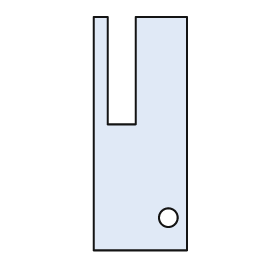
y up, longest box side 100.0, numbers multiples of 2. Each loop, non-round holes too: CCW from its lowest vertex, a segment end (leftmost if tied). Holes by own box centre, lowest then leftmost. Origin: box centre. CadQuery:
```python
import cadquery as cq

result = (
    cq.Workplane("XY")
    .moveTo(-20.0, -50.0)
    .lineTo(20.0, -50.0)
    .lineTo(20.0, 50.0)
    .lineTo(-2.0, 50.0)
    .lineTo(-2.0, 4.0)
    .lineTo(-14.0, 4.0)
    .lineTo(-14.0, 50.0)
    .lineTo(-20.0, 50.0)
    .close()
    .moveTo(12.0, -36.0)
    .circle(4.0)
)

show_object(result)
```